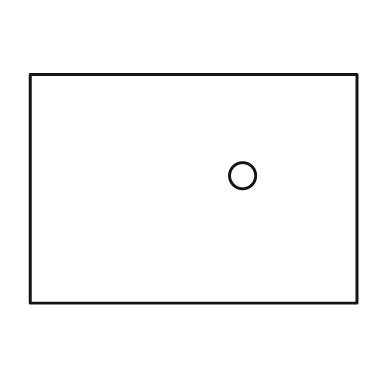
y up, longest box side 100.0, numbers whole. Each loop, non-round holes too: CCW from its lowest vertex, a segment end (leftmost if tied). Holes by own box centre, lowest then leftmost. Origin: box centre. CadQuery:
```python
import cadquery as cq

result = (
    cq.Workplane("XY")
    .moveTo(-50.0, -35.0)
    .lineTo(50.0, -35.0)
    .lineTo(50.0, 35.0)
    .lineTo(-50.0, 35.0)
    .close()
    .moveTo(15.0, 4.0)
    .circle(4.0)
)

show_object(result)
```